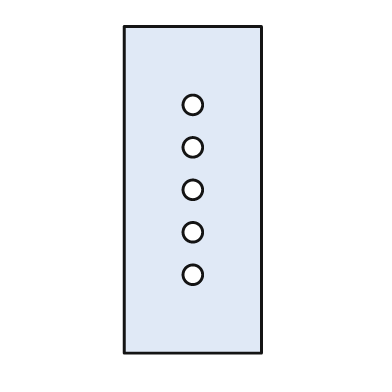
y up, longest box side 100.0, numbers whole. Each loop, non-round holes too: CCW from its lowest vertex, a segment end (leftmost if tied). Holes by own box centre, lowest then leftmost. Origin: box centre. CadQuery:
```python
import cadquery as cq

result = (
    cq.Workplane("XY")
    .moveTo(-21.0, -50.0)
    .lineTo(21.0, -50.0)
    .lineTo(21.0, 50.0)
    .lineTo(-21.0, 50.0)
    .close()
    .moveTo(0.0, -26.0)
    .circle(3.0)
    .moveTo(0.0, -13.0)
    .circle(3.0)
    .moveTo(0.0, 0.0)
    .circle(3.0)
    .moveTo(0.0, 13.0)
    .circle(3.0)
    .moveTo(0.0, 26.0)
    .circle(3.0)
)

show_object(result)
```